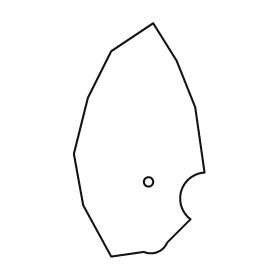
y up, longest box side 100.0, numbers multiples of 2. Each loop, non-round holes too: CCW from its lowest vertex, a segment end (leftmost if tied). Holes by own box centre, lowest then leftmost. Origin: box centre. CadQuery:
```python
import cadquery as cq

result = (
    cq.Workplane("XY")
    .moveTo(-12.0, -50.0)
    .lineTo(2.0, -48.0)
    .threePointArc((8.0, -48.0), (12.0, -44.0))
    .lineTo(22.0, -34.0)
    .threePointArc((18.0, -22.0), (28.0, -14.0))
    .lineTo(24.0, 14.0)
    .lineTo(16.0, 34.0)
    .lineTo(6.0, 50.0)
    .lineTo(-12.0, 38.0)
    .lineTo(-22.0, 18.0)
    .lineTo(-28.0, -6.0)
    .lineTo(-24.0, -28.0)
    .close()
    .moveTo(4.0, -18.0)
    .circle(2.0)
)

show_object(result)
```